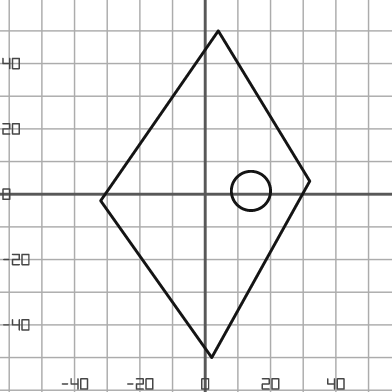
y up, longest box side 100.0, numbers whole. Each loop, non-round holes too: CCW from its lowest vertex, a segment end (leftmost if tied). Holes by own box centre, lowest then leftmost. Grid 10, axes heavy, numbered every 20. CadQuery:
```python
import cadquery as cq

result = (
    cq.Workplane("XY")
    .moveTo(2.0, -50.0)
    .lineTo(32.0, 4.0)
    .lineTo(4.0, 50.0)
    .lineTo(-32.0, -2.0)
    .close()
    .moveTo(14.0, 1.0)
    .circle(6.0)
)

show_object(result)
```